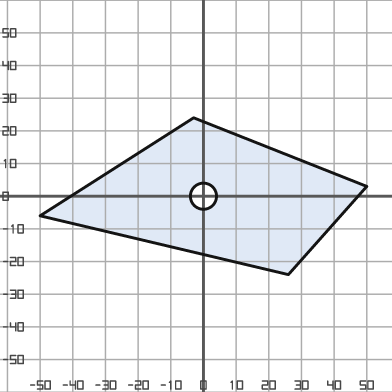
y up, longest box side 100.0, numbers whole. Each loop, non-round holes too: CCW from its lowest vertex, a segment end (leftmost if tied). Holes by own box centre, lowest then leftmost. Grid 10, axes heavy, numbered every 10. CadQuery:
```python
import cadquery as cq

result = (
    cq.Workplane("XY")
    .moveTo(26.0, -24.0)
    .lineTo(50.0, 3.0)
    .lineTo(-3.0, 24.0)
    .lineTo(-50.0, -6.0)
    .close()
    .moveTo(0.0, 0.0)
    .circle(4.0)
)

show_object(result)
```